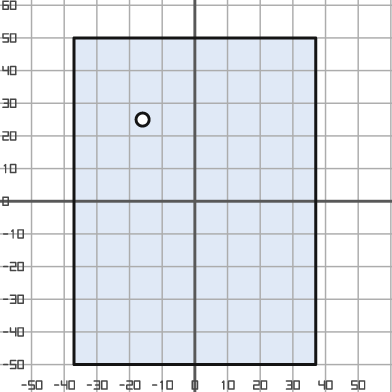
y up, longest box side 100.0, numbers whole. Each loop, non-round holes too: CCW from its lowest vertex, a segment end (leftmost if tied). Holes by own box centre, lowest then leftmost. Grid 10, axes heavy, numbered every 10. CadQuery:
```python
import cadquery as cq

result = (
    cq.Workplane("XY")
    .moveTo(-37.0, -50.0)
    .lineTo(37.0, -50.0)
    .lineTo(37.0, 50.0)
    .lineTo(-37.0, 50.0)
    .close()
    .moveTo(-16.0, 25.0)
    .circle(2.0)
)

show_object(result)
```